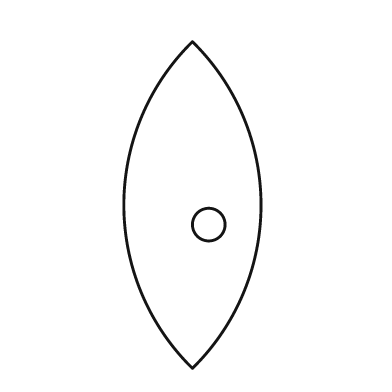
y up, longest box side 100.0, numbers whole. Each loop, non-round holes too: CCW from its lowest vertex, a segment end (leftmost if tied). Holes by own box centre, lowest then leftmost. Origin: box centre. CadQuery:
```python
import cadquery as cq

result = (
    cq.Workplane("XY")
    .moveTo(0.0, -50.0)
    .threePointArc((21.0, 0.0), (0.0, 50.0))
    .threePointArc((-21.0, 0.0), (0.0, -50.0))
    .close()
    .moveTo(5.0, -6.0)
    .circle(5.0)
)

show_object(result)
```